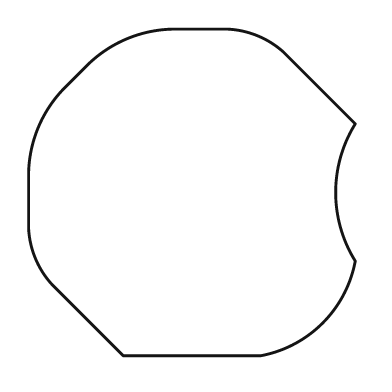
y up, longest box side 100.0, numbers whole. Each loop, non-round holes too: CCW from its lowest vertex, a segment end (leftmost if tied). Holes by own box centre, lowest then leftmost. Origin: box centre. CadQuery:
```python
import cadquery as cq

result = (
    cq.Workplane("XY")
    .moveTo(-21.0, -50.0)
    .lineTo(21.0, -50.0)
    .threePointArc((40.0, -40.0), (50.0, -21.0))
    .threePointArc((44.0, 0.0), (50.0, 21.0))
    .lineTo(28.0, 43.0)
    .threePointArc((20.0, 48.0), (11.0, 50.0))
    .lineTo(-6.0, 50.0)
    .threePointArc((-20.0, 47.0), (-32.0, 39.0))
    .lineTo(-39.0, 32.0)
    .threePointArc((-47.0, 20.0), (-50.0, 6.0))
    .lineTo(-50.0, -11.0)
    .threePointArc((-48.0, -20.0), (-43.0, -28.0))
    .close()
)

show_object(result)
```